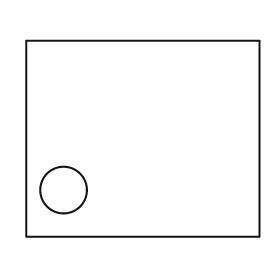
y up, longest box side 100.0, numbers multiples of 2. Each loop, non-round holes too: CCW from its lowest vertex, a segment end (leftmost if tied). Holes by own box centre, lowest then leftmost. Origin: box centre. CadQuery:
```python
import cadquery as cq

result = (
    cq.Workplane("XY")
    .moveTo(-50.0, -42.0)
    .lineTo(50.0, -42.0)
    .lineTo(50.0, 42.0)
    .lineTo(-50.0, 42.0)
    .close()
    .moveTo(-34.0, -22.0)
    .circle(10.0)
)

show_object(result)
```